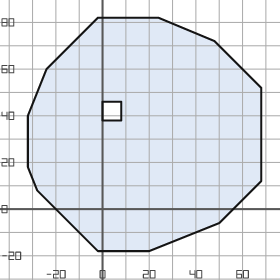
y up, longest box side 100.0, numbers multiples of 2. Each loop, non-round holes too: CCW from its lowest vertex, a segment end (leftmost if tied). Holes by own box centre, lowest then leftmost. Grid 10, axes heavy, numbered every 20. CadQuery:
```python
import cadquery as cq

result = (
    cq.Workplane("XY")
    .moveTo(-2.0, -18.0)
    .lineTo(20.0, -18.0)
    .lineTo(50.0, -6.0)
    .lineTo(68.0, 12.0)
    .lineTo(68.0, 52.0)
    .lineTo(48.0, 72.0)
    .lineTo(24.0, 82.0)
    .lineTo(-2.0, 82.0)
    .lineTo(-24.0, 60.0)
    .lineTo(-32.0, 40.0)
    .lineTo(-32.0, 18.0)
    .lineTo(-28.0, 8.0)
    .close()
    .moveTo(0.0, 38.0)
    .lineTo(8.0, 38.0)
    .lineTo(8.0, 46.0)
    .lineTo(0.0, 46.0)
    .close()
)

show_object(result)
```